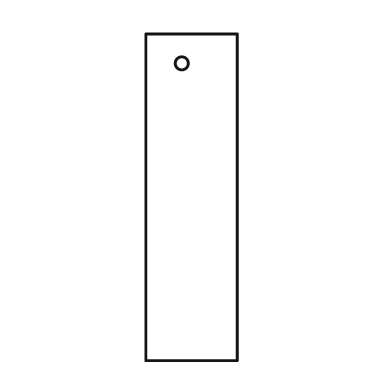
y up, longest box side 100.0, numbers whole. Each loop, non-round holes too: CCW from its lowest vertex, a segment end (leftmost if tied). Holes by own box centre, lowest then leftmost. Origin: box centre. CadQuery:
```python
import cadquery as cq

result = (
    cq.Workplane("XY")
    .moveTo(-14.0, -50.0)
    .lineTo(14.0, -50.0)
    .lineTo(14.0, 50.0)
    .lineTo(-14.0, 50.0)
    .close()
    .moveTo(-3.0, 41.0)
    .circle(2.0)
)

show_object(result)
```